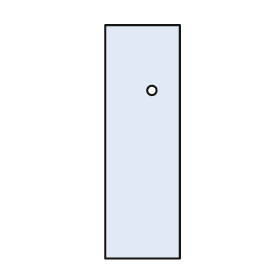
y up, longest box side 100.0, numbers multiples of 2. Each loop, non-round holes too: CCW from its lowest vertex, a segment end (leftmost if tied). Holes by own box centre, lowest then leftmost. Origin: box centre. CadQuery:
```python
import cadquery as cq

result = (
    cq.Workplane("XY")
    .moveTo(-16.0, -50.0)
    .lineTo(16.0, -50.0)
    .lineTo(16.0, 50.0)
    .lineTo(-16.0, 50.0)
    .close()
    .moveTo(4.0, 22.0)
    .circle(2.0)
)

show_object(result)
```